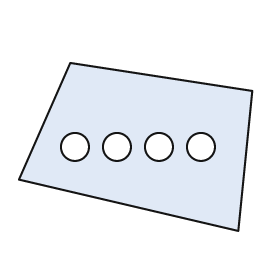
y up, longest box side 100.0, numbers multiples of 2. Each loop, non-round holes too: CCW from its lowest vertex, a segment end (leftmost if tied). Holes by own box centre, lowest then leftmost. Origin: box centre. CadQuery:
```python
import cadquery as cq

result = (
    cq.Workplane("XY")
    .moveTo(44.0, -36.0)
    .lineTo(50.0, 24.0)
    .lineTo(-28.0, 36.0)
    .lineTo(-50.0, -14.0)
    .close()
    .moveTo(-26.0, 0.0)
    .circle(6.0)
    .moveTo(-8.0, 0.0)
    .circle(6.0)
    .moveTo(10.0, 0.0)
    .circle(6.0)
    .moveTo(28.0, 0.0)
    .circle(6.0)
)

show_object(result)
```